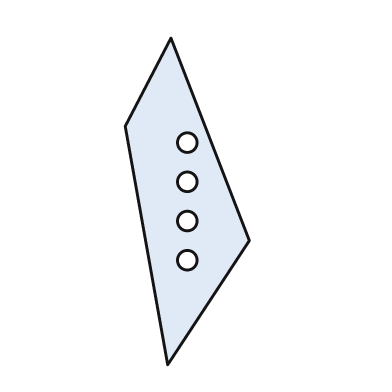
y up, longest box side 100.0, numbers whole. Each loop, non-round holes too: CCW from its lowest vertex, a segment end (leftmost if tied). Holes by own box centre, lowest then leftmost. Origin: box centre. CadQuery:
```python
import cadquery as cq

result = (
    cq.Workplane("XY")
    .moveTo(-6.0, -50.0)
    .lineTo(19.0, -12.0)
    .lineTo(-5.0, 50.0)
    .lineTo(-19.0, 23.0)
    .close()
    .moveTo(0.0, -18.0)
    .circle(3.0)
    .moveTo(0.0, -6.0)
    .circle(3.0)
    .moveTo(0.0, 6.0)
    .circle(3.0)
    .moveTo(0.0, 18.0)
    .circle(3.0)
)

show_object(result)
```